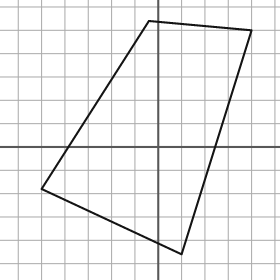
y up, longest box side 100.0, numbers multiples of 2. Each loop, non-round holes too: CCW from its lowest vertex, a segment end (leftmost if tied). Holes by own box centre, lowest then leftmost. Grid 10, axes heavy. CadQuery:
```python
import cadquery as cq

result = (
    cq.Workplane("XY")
    .moveTo(10.0, -46.0)
    .lineTo(40.0, 50.0)
    .lineTo(-4.0, 54.0)
    .lineTo(-50.0, -18.0)
    .close()
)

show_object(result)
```